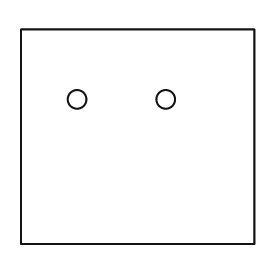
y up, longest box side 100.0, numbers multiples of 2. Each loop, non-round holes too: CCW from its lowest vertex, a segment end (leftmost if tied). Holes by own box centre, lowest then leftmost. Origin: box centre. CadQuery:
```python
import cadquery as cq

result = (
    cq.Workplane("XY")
    .moveTo(-50.0, -46.0)
    .lineTo(50.0, -46.0)
    .lineTo(50.0, 46.0)
    .lineTo(-50.0, 46.0)
    .close()
    .moveTo(-26.0, 16.0)
    .circle(4.0)
    .moveTo(12.0, 16.0)
    .circle(4.0)
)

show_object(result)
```